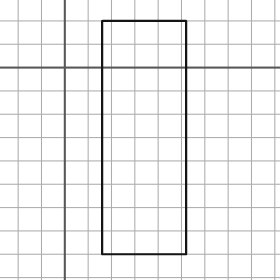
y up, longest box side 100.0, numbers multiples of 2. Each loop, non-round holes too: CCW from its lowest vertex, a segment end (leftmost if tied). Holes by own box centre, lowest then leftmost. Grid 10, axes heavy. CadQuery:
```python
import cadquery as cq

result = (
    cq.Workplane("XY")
    .moveTo(16.0, -80.0)
    .lineTo(52.0, -80.0)
    .lineTo(52.0, 20.0)
    .lineTo(16.0, 20.0)
    .close()
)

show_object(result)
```